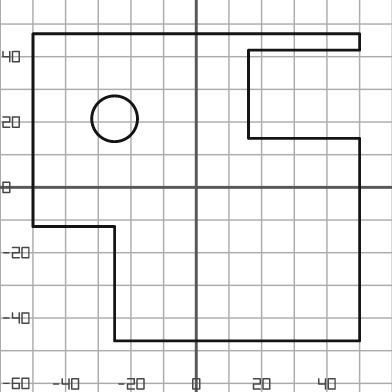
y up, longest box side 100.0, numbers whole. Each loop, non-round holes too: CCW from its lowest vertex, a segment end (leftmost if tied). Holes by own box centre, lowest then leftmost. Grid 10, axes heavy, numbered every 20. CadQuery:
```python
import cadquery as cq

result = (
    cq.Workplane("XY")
    .moveTo(-25.0, -47.0)
    .lineTo(50.0, -47.0)
    .lineTo(50.0, 15.0)
    .lineTo(16.0, 15.0)
    .lineTo(16.0, 42.0)
    .lineTo(50.0, 42.0)
    .lineTo(50.0, 47.0)
    .lineTo(-50.0, 47.0)
    .lineTo(-50.0, -12.0)
    .lineTo(-25.0, -12.0)
    .close()
    .moveTo(-25.0, 21.0)
    .circle(7.0)
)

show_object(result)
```